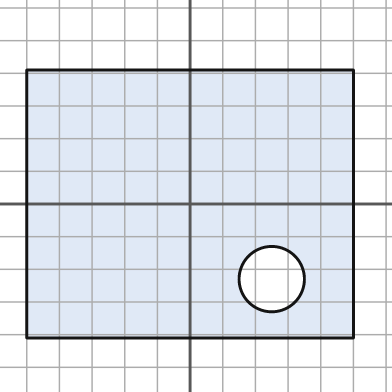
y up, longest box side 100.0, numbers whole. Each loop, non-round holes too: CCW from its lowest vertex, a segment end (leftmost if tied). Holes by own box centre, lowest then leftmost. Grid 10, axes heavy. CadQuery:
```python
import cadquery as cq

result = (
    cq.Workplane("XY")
    .moveTo(-50.0, -41.0)
    .lineTo(50.0, -41.0)
    .lineTo(50.0, 41.0)
    .lineTo(-50.0, 41.0)
    .close()
    .moveTo(25.0, -23.0)
    .circle(10.0)
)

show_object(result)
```